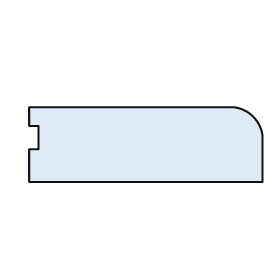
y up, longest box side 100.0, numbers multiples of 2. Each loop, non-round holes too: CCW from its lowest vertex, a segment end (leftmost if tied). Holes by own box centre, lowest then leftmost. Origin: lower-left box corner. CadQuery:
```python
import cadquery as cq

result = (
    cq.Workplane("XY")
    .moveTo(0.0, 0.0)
    .lineTo(100.0, 0.0)
    .lineTo(100.0, 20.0)
    .threePointArc((96.0, 28.0), (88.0, 32.0))
    .lineTo(0.0, 32.0)
    .lineTo(0.0, 24.0)
    .lineTo(4.0, 24.0)
    .lineTo(4.0, 14.0)
    .lineTo(0.0, 14.0)
    .close()
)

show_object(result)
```